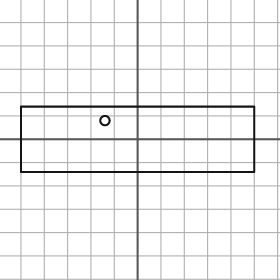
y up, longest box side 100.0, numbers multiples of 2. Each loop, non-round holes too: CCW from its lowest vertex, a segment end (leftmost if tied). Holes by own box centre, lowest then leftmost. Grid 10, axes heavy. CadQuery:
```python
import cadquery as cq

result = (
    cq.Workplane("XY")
    .moveTo(-50.0, -14.0)
    .lineTo(50.0, -14.0)
    .lineTo(50.0, 14.0)
    .lineTo(-50.0, 14.0)
    .close()
    .moveTo(-14.0, 8.0)
    .circle(2.0)
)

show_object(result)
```